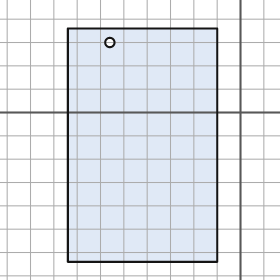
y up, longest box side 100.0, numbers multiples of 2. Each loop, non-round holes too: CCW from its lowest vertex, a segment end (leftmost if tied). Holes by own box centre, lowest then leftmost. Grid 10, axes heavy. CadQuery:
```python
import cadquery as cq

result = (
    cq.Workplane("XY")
    .moveTo(-74.0, -64.0)
    .lineTo(-10.0, -64.0)
    .lineTo(-10.0, 36.0)
    .lineTo(-74.0, 36.0)
    .close()
    .moveTo(-56.0, 30.0)
    .circle(2.0)
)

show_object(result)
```